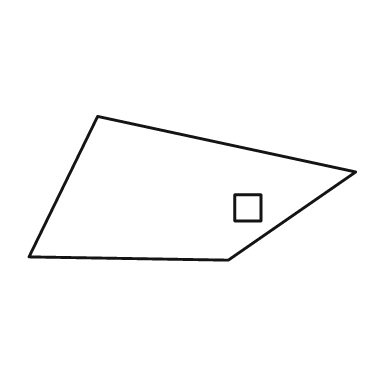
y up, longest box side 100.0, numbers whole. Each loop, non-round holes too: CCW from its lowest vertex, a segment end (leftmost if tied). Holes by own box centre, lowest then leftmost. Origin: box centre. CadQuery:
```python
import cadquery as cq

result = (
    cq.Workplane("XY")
    .moveTo(11.0, -22.0)
    .lineTo(50.0, 5.0)
    .lineTo(-29.0, 22.0)
    .lineTo(-50.0, -21.0)
    .close()
    .moveTo(13.0, -10.0)
    .lineTo(21.0, -10.0)
    .lineTo(21.0, -2.0)
    .lineTo(13.0, -2.0)
    .close()
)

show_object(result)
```